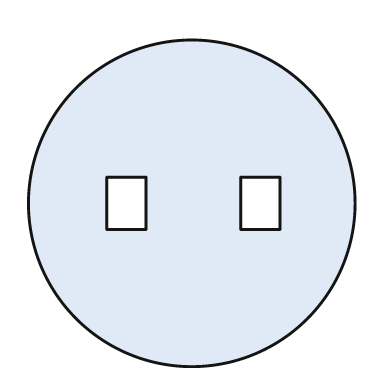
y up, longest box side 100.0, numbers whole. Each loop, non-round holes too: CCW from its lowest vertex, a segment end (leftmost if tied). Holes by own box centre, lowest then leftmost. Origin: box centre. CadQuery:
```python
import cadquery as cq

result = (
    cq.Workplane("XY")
    .moveTo(0.0, 0.0)
    .circle(50.0)
    .moveTo(-26.0, -8.0)
    .lineTo(-14.0, -8.0)
    .lineTo(-14.0, 8.0)
    .lineTo(-26.0, 8.0)
    .close()
    .moveTo(15.0, -8.0)
    .lineTo(27.0, -8.0)
    .lineTo(27.0, 8.0)
    .lineTo(15.0, 8.0)
    .close()
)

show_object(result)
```